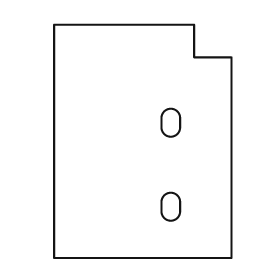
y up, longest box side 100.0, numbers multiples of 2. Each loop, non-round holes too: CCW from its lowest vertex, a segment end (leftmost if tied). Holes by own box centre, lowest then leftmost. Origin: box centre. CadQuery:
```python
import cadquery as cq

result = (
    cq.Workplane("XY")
    .moveTo(-38.0, -50.0)
    .lineTo(38.0, -50.0)
    .lineTo(38.0, 36.0)
    .lineTo(22.0, 36.0)
    .lineTo(22.0, 50.0)
    .lineTo(-38.0, 50.0)
    .close()
    .moveTo(8.0, -30.0)
    .threePointArc((12.0, -34.0), (16.0, -30.0))
    .lineTo(16.0, -26.0)
    .threePointArc((12.0, -22.0), (8.0, -26.0))
    .close()
    .moveTo(8.0, 6.0)
    .threePointArc((12.0, 2.0), (16.0, 6.0))
    .lineTo(16.0, 10.0)
    .threePointArc((12.0, 14.0), (8.0, 10.0))
    .close()
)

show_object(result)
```